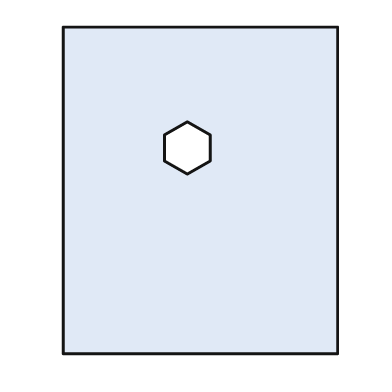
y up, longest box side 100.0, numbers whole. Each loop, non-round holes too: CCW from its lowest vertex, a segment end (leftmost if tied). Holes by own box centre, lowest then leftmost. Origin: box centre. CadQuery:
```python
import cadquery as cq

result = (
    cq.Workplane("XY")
    .moveTo(-42.0, -50.0)
    .lineTo(42.0, -50.0)
    .lineTo(42.0, 50.0)
    .lineTo(-42.0, 50.0)
    .close()
    .moveTo(-4.0, 5.0)
    .lineTo(3.0, 9.0)
    .lineTo(3.0, 17.0)
    .lineTo(-4.0, 21.0)
    .lineTo(-11.0, 17.0)
    .lineTo(-11.0, 9.0)
    .close()
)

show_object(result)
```